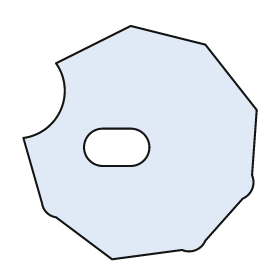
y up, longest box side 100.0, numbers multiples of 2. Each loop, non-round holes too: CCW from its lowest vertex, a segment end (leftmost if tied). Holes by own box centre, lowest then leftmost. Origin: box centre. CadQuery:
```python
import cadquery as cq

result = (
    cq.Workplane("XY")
    .moveTo(-12.0, -50.0)
    .lineTo(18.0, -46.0)
    .threePointArc((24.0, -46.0), (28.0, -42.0))
    .lineTo(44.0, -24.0)
    .threePointArc((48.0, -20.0), (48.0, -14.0))
    .lineTo(50.0, 14.0)
    .lineTo(28.0, 42.0)
    .lineTo(-4.0, 50.0)
    .lineTo(-36.0, 34.0)
    .threePointArc((-34.0, 14.0), (-50.0, 2.0))
    .lineTo(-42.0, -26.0)
    .threePointArc((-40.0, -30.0), (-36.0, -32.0))
    .close()
    .moveTo(-16.0, -10.0)
    .lineTo(-4.0, -10.0)
    .threePointArc((4.0, -2.0), (-4.0, 6.0))
    .lineTo(-16.0, 6.0)
    .threePointArc((-24.0, -2.0), (-16.0, -10.0))
    .close()
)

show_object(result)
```